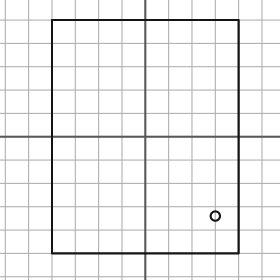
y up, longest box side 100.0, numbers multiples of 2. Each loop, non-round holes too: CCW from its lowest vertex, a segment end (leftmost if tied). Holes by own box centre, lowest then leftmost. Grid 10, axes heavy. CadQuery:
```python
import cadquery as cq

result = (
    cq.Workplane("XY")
    .moveTo(-40.0, -50.0)
    .lineTo(40.0, -50.0)
    .lineTo(40.0, 50.0)
    .lineTo(-40.0, 50.0)
    .close()
    .moveTo(30.0, -34.0)
    .circle(2.0)
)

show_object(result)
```